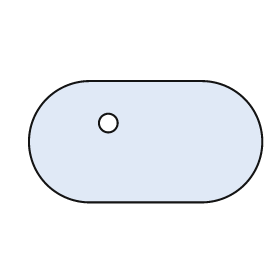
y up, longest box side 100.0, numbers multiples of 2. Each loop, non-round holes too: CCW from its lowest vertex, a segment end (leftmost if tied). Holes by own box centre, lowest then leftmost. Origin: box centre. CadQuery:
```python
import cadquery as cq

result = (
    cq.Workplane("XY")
    .moveTo(-24.0, -26.0)
    .lineTo(24.0, -26.0)
    .threePointArc((50.0, 0.0), (24.0, 26.0))
    .lineTo(-24.0, 26.0)
    .threePointArc((-50.0, 0.0), (-24.0, -26.0))
    .close()
    .moveTo(-16.0, 8.0)
    .circle(4.0)
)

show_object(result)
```